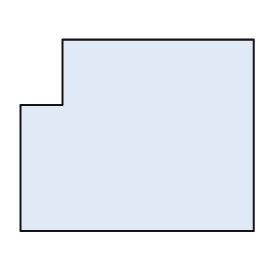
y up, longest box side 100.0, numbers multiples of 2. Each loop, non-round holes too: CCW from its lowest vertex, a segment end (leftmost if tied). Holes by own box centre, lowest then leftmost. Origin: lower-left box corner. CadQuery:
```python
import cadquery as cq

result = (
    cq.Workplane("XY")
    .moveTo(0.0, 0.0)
    .lineTo(100.0, 0.0)
    .lineTo(100.0, 82.0)
    .lineTo(18.0, 82.0)
    .lineTo(18.0, 54.0)
    .lineTo(0.0, 54.0)
    .close()
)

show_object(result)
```